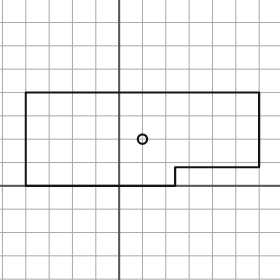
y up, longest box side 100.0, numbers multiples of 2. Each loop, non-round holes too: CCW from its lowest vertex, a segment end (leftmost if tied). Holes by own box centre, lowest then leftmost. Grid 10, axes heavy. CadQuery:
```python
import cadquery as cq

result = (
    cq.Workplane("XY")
    .moveTo(-40.0, 0.0)
    .lineTo(24.0, 0.0)
    .lineTo(24.0, 8.0)
    .lineTo(60.0, 8.0)
    .lineTo(60.0, 40.0)
    .lineTo(-40.0, 40.0)
    .close()
    .moveTo(10.0, 20.0)
    .circle(2.0)
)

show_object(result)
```